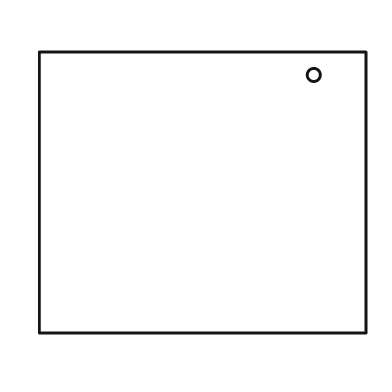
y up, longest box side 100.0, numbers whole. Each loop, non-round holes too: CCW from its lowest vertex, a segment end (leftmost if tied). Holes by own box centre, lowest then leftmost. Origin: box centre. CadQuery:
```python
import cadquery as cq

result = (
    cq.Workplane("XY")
    .moveTo(-50.0, -43.0)
    .lineTo(50.0, -43.0)
    .lineTo(50.0, 43.0)
    .lineTo(-50.0, 43.0)
    .close()
    .moveTo(34.0, 36.0)
    .circle(2.0)
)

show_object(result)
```